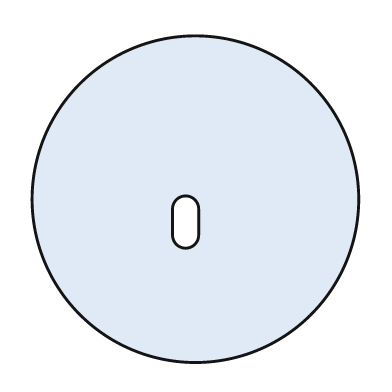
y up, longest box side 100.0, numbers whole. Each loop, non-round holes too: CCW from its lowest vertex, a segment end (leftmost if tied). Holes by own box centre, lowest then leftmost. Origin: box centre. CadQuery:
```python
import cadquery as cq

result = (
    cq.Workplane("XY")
    .moveTo(0.0, 0.0)
    .circle(50.0)
    .moveTo(-7.0, -11.0)
    .threePointArc((-3.0, -15.0), (1.0, -11.0))
    .lineTo(1.0, -3.0)
    .threePointArc((-3.0, 1.0), (-7.0, -3.0))
    .close()
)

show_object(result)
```